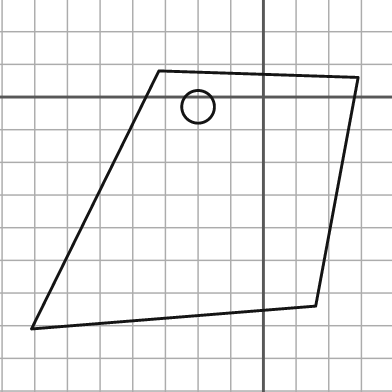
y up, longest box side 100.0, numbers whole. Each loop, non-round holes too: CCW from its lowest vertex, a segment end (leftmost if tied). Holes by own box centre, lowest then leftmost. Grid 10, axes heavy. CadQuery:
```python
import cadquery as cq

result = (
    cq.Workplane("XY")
    .moveTo(-71.0, -71.0)
    .lineTo(16.0, -64.0)
    .lineTo(29.0, 6.0)
    .lineTo(-32.0, 8.0)
    .close()
    .moveTo(-20.0, -3.0)
    .circle(5.0)
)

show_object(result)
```